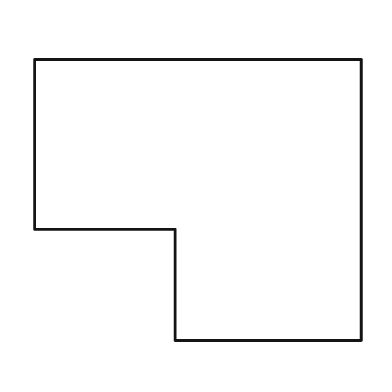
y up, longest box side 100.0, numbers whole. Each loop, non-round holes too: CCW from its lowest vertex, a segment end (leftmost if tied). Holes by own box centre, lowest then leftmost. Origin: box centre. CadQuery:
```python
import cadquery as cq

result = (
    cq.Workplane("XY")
    .moveTo(-7.0, -43.0)
    .lineTo(50.0, -43.0)
    .lineTo(50.0, 43.0)
    .lineTo(-50.0, 43.0)
    .lineTo(-50.0, -9.0)
    .lineTo(-7.0, -9.0)
    .close()
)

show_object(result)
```